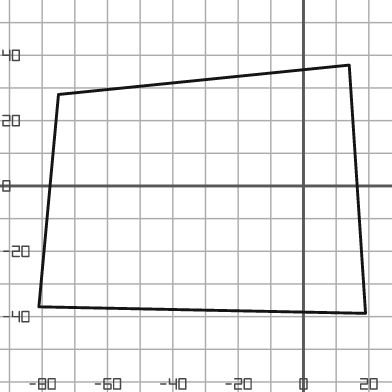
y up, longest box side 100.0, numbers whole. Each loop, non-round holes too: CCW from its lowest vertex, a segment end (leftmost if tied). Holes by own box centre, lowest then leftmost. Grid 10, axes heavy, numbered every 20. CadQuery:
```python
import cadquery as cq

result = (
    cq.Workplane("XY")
    .moveTo(19.0, -39.0)
    .lineTo(14.0, 37.0)
    .lineTo(-75.0, 28.0)
    .lineTo(-81.0, -37.0)
    .close()
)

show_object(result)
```